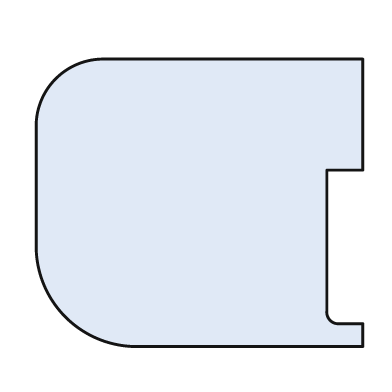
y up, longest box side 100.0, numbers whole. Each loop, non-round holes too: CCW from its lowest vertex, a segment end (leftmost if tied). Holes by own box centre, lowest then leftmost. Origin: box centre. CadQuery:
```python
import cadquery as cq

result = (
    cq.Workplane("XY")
    .moveTo(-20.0, -44.0)
    .lineTo(50.0, -44.0)
    .lineTo(50.0, -37.0)
    .lineTo(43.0, -37.0)
    .threePointArc((40.0, -36.0), (39.0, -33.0))
    .lineTo(39.0, 10.0)
    .lineTo(50.0, 10.0)
    .lineTo(50.0, 44.0)
    .lineTo(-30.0, 44.0)
    .threePointArc((-44.0, 38.0), (-50.0, 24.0))
    .lineTo(-50.0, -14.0)
    .threePointArc((-41.0, -35.0), (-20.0, -44.0))
    .close()
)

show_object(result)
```